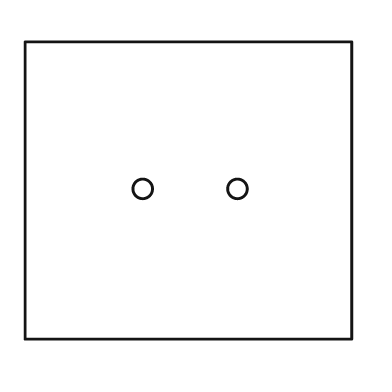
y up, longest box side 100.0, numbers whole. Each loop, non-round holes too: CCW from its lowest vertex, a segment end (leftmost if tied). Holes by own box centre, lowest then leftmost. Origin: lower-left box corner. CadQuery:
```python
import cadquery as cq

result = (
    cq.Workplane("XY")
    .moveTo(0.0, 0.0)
    .lineTo(100.0, 0.0)
    .lineTo(100.0, 91.0)
    .lineTo(0.0, 91.0)
    .close()
    .moveTo(36.0, 46.0)
    .circle(3.0)
    .moveTo(65.0, 46.0)
    .circle(3.0)
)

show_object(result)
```